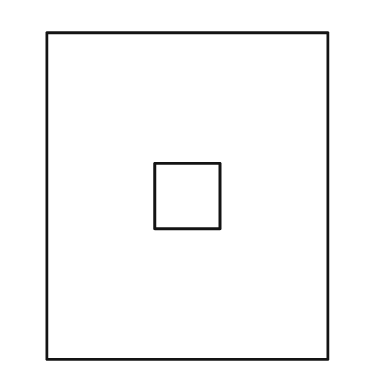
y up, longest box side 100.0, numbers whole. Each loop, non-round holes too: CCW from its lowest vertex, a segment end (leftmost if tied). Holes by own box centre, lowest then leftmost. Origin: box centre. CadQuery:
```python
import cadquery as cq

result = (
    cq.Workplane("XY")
    .moveTo(-43.0, -50.0)
    .lineTo(43.0, -50.0)
    .lineTo(43.0, 50.0)
    .lineTo(-43.0, 50.0)
    .close()
    .moveTo(-10.0, -10.0)
    .lineTo(10.0, -10.0)
    .lineTo(10.0, 10.0)
    .lineTo(-10.0, 10.0)
    .close()
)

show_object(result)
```